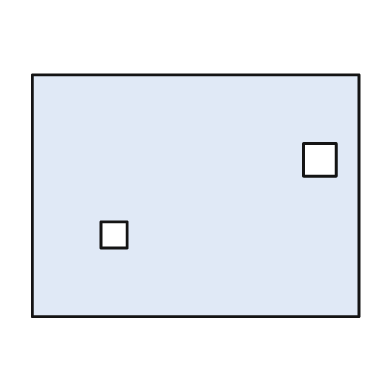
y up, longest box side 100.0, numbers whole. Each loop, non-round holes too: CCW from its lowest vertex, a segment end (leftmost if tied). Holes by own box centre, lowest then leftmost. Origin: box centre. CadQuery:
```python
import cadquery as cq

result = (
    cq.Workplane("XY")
    .moveTo(-50.0, -37.0)
    .lineTo(50.0, -37.0)
    .lineTo(50.0, 37.0)
    .lineTo(-50.0, 37.0)
    .close()
    .moveTo(-29.0, -16.0)
    .lineTo(-21.0, -16.0)
    .lineTo(-21.0, -8.0)
    .lineTo(-29.0, -8.0)
    .close()
    .moveTo(33.0, 6.0)
    .lineTo(43.0, 6.0)
    .lineTo(43.0, 16.0)
    .lineTo(33.0, 16.0)
    .close()
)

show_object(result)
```